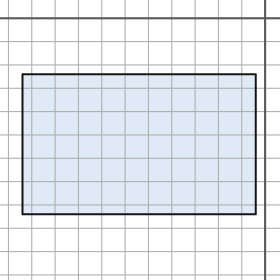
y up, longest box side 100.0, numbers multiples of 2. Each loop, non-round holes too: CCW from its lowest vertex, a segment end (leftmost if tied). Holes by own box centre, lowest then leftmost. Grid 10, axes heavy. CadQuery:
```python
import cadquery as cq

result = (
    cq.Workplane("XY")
    .moveTo(-104.0, -84.0)
    .lineTo(-4.0, -84.0)
    .lineTo(-4.0, -24.0)
    .lineTo(-104.0, -24.0)
    .close()
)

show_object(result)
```